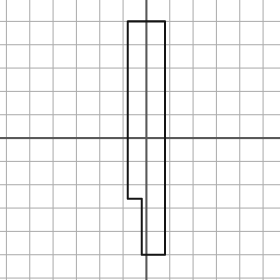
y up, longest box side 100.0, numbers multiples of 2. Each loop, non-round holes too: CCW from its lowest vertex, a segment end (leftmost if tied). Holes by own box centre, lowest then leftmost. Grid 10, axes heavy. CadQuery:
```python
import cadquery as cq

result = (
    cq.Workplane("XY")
    .moveTo(-2.0, -50.0)
    .lineTo(8.0, -50.0)
    .lineTo(8.0, 50.0)
    .lineTo(-8.0, 50.0)
    .lineTo(-8.0, -26.0)
    .lineTo(-2.0, -26.0)
    .close()
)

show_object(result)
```